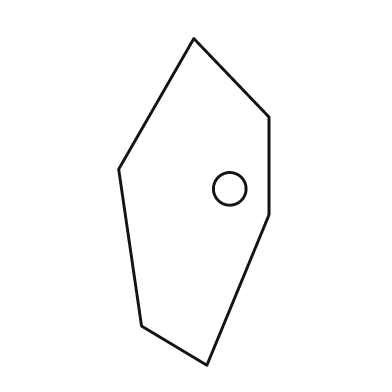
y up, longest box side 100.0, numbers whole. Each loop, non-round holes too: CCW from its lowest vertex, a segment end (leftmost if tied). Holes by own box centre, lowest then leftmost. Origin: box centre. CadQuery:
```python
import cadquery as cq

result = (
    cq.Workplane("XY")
    .moveTo(4.0, -50.0)
    .lineTo(23.0, -4.0)
    .lineTo(23.0, 26.0)
    .lineTo(0.0, 50.0)
    .lineTo(-23.0, 10.0)
    .lineTo(-16.0, -38.0)
    .close()
    .moveTo(11.0, 4.0)
    .circle(5.0)
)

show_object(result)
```